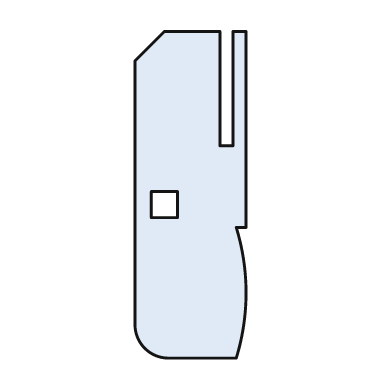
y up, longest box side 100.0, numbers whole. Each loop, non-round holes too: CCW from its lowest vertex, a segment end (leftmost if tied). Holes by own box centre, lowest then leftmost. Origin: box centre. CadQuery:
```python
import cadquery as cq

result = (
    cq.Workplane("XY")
    .moveTo(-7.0, -50.0)
    .lineTo(14.0, -50.0)
    .threePointArc((17.0, -30.0), (14.0, -10.0))
    .lineTo(17.0, -10.0)
    .lineTo(17.0, 50.0)
    .lineTo(13.0, 50.0)
    .lineTo(13.0, 15.0)
    .lineTo(9.0, 15.0)
    .lineTo(9.0, 50.0)
    .lineTo(-8.0, 50.0)
    .lineTo(-17.0, 41.0)
    .lineTo(-17.0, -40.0)
    .threePointArc((-14.0, -47.0), (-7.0, -50.0))
    .close()
    .moveTo(-12.0, -7.0)
    .lineTo(-4.0, -7.0)
    .lineTo(-4.0, 1.0)
    .lineTo(-12.0, 1.0)
    .close()
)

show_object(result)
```